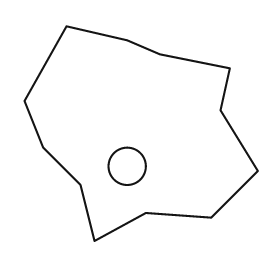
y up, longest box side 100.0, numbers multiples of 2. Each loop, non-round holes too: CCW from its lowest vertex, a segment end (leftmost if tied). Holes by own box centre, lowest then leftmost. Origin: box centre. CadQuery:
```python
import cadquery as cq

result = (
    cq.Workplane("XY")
    .moveTo(-20.0, -46.0)
    .lineTo(2.0, -34.0)
    .lineTo(30.0, -36.0)
    .lineTo(50.0, -16.0)
    .lineTo(34.0, 10.0)
    .lineTo(38.0, 28.0)
    .lineTo(8.0, 34.0)
    .lineTo(-6.0, 40.0)
    .lineTo(-32.0, 46.0)
    .lineTo(-50.0, 14.0)
    .lineTo(-42.0, -6.0)
    .lineTo(-26.0, -22.0)
    .close()
    .moveTo(-6.0, -14.0)
    .circle(8.0)
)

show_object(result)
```